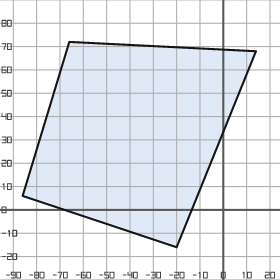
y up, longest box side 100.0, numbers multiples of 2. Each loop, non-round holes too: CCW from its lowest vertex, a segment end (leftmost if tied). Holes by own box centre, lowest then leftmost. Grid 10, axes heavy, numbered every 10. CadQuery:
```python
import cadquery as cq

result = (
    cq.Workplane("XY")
    .moveTo(-20.0, -16.0)
    .lineTo(14.0, 68.0)
    .lineTo(-66.0, 72.0)
    .lineTo(-86.0, 6.0)
    .close()
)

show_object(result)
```